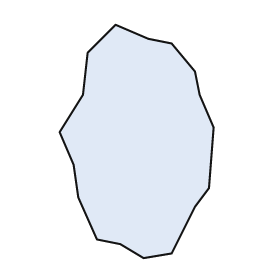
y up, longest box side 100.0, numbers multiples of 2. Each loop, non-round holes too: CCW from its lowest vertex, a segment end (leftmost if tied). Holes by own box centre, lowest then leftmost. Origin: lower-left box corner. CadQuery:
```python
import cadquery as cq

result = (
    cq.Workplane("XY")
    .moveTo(36.0, 0.0)
    .lineTo(48.0, 2.0)
    .lineTo(58.0, 22.0)
    .lineTo(64.0, 30.0)
    .lineTo(66.0, 56.0)
    .lineTo(60.0, 70.0)
    .lineTo(58.0, 80.0)
    .lineTo(48.0, 92.0)
    .lineTo(38.0, 94.0)
    .lineTo(24.0, 100.0)
    .lineTo(12.0, 88.0)
    .lineTo(10.0, 70.0)
    .lineTo(0.0, 54.0)
    .lineTo(6.0, 40.0)
    .lineTo(8.0, 26.0)
    .lineTo(16.0, 8.0)
    .lineTo(26.0, 6.0)
    .close()
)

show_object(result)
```